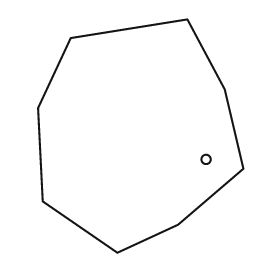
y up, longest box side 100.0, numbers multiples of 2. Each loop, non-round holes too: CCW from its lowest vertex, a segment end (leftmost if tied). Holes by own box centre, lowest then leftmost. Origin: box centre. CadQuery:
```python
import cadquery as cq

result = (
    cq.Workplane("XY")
    .moveTo(-10.0, -50.0)
    .lineTo(16.0, -38.0)
    .lineTo(44.0, -14.0)
    .lineTo(36.0, 20.0)
    .lineTo(20.0, 50.0)
    .lineTo(-30.0, 42.0)
    .lineTo(-44.0, 12.0)
    .lineTo(-42.0, -28.0)
    .close()
    .moveTo(28.0, -10.0)
    .circle(2.0)
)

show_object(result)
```